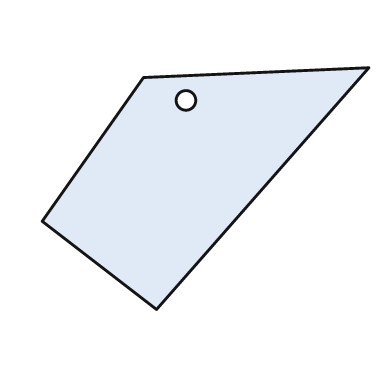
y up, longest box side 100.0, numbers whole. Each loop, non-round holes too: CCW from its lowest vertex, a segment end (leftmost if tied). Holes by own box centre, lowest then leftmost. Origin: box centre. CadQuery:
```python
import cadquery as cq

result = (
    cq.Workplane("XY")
    .moveTo(-15.0, -37.0)
    .lineTo(50.0, 37.0)
    .lineTo(-19.0, 34.0)
    .lineTo(-50.0, -10.0)
    .close()
    .moveTo(-6.0, 27.0)
    .circle(3.0)
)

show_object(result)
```